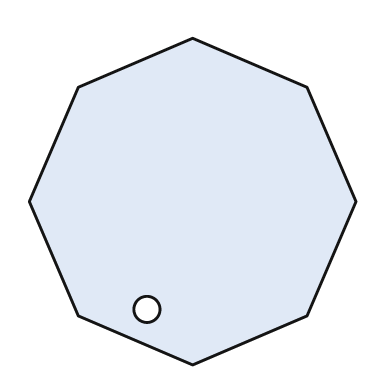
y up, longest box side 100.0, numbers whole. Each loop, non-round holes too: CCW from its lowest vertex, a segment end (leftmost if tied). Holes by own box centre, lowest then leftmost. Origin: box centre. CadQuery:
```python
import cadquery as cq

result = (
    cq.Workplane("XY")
    .moveTo(0.0, -50.0)
    .lineTo(35.0, -35.0)
    .lineTo(50.0, 0.0)
    .lineTo(35.0, 35.0)
    .lineTo(0.0, 50.0)
    .lineTo(-35.0, 35.0)
    .lineTo(-50.0, 0.0)
    .lineTo(-35.0, -35.0)
    .close()
    .moveTo(-14.0, -33.0)
    .circle(4.0)
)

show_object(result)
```